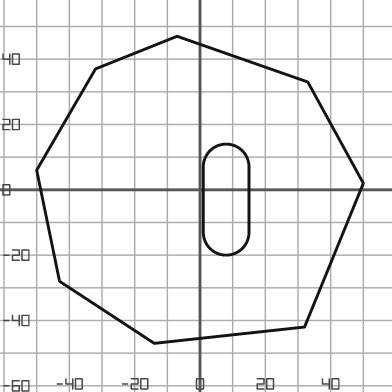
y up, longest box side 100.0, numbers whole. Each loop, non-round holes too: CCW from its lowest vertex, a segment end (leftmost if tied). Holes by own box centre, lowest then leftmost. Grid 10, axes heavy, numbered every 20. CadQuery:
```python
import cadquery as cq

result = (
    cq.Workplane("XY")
    .moveTo(-14.0, -47.0)
    .lineTo(32.0, -42.0)
    .lineTo(50.0, 2.0)
    .lineTo(33.0, 33.0)
    .lineTo(-7.0, 47.0)
    .lineTo(-32.0, 37.0)
    .lineTo(-50.0, 6.0)
    .lineTo(-43.0, -28.0)
    .close()
    .moveTo(1.0, -13.0)
    .threePointArc((8.0, -20.0), (15.0, -13.0))
    .lineTo(15.0, 7.0)
    .threePointArc((8.0, 14.0), (1.0, 7.0))
    .close()
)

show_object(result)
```